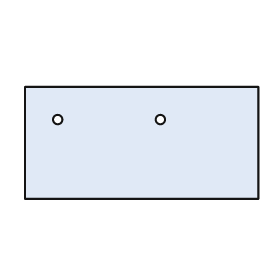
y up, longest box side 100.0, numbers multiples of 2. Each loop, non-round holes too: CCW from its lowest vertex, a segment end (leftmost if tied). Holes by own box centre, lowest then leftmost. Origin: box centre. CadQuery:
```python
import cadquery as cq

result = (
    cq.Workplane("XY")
    .moveTo(-50.0, -24.0)
    .lineTo(50.0, -24.0)
    .lineTo(50.0, 24.0)
    .lineTo(-50.0, 24.0)
    .close()
    .moveTo(-36.0, 10.0)
    .circle(2.0)
    .moveTo(8.0, 10.0)
    .circle(2.0)
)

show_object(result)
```